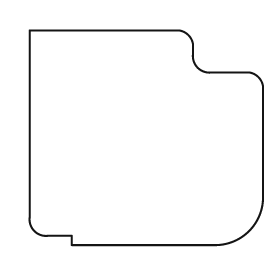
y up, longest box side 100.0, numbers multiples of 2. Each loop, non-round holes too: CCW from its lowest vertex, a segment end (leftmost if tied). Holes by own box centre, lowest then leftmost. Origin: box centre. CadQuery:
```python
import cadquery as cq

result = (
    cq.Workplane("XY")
    .moveTo(-32.0, -46.0)
    .lineTo(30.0, -46.0)
    .threePointArc((44.0, -40.0), (50.0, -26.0))
    .lineTo(50.0, 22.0)
    .threePointArc((48.0, 26.0), (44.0, 28.0))
    .lineTo(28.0, 28.0)
    .threePointArc((22.0, 30.0), (20.0, 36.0))
    .lineTo(20.0, 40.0)
    .threePointArc((18.0, 44.0), (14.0, 46.0))
    .lineTo(-50.0, 46.0)
    .lineTo(-50.0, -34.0)
    .threePointArc((-48.0, -40.0), (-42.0, -42.0))
    .lineTo(-32.0, -42.0)
    .close()
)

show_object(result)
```